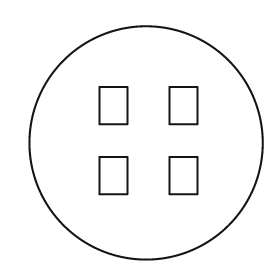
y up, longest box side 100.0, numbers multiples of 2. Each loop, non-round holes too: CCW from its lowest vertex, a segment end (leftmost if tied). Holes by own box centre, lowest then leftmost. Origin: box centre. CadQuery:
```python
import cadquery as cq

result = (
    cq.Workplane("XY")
    .moveTo(0.0, 0.0)
    .circle(50.0)
    .moveTo(-20.0, -22.0)
    .lineTo(-8.0, -22.0)
    .lineTo(-8.0, -6.0)
    .lineTo(-20.0, -6.0)
    .close()
    .moveTo(10.0, -22.0)
    .lineTo(22.0, -22.0)
    .lineTo(22.0, -6.0)
    .lineTo(10.0, -6.0)
    .close()
    .moveTo(-20.0, 8.0)
    .lineTo(-8.0, 8.0)
    .lineTo(-8.0, 24.0)
    .lineTo(-20.0, 24.0)
    .close()
    .moveTo(10.0, 8.0)
    .lineTo(22.0, 8.0)
    .lineTo(22.0, 24.0)
    .lineTo(10.0, 24.0)
    .close()
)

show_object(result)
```